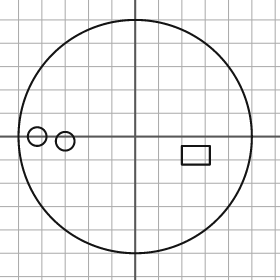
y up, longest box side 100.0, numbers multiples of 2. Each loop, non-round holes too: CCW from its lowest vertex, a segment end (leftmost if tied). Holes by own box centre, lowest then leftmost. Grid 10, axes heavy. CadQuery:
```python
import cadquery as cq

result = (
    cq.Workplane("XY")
    .moveTo(0.0, 0.0)
    .circle(50.0)
    .moveTo(20.0, -12.0)
    .lineTo(32.0, -12.0)
    .lineTo(32.0, -4.0)
    .lineTo(20.0, -4.0)
    .close()
    .moveTo(-30.0, -2.0)
    .circle(4.0)
    .moveTo(-42.0, 0.0)
    .circle(4.0)
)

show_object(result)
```